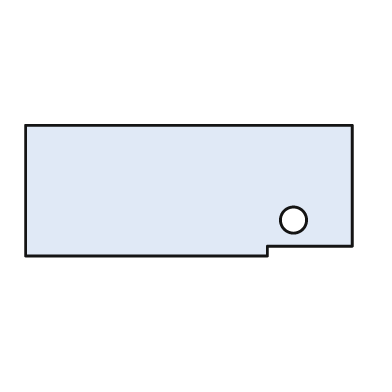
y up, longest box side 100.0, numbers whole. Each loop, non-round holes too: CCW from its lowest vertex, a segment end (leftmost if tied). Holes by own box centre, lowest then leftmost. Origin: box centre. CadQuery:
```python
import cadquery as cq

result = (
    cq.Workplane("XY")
    .moveTo(-50.0, -20.0)
    .lineTo(24.0, -20.0)
    .lineTo(24.0, -17.0)
    .lineTo(50.0, -17.0)
    .lineTo(50.0, 20.0)
    .lineTo(-50.0, 20.0)
    .close()
    .moveTo(32.0, -9.0)
    .circle(4.0)
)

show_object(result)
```